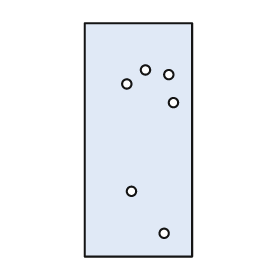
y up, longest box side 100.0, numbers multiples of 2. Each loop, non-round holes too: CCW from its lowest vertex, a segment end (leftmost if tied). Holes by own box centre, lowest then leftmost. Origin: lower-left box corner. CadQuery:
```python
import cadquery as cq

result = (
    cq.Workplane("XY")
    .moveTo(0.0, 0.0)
    .lineTo(46.0, 0.0)
    .lineTo(46.0, 100.0)
    .lineTo(0.0, 100.0)
    .close()
    .moveTo(34.0, 10.0)
    .circle(2.0)
    .moveTo(20.0, 28.0)
    .circle(2.0)
    .moveTo(38.0, 66.0)
    .circle(2.0)
    .moveTo(18.0, 74.0)
    .circle(2.0)
    .moveTo(36.0, 78.0)
    .circle(2.0)
    .moveTo(26.0, 80.0)
    .circle(2.0)
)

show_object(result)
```